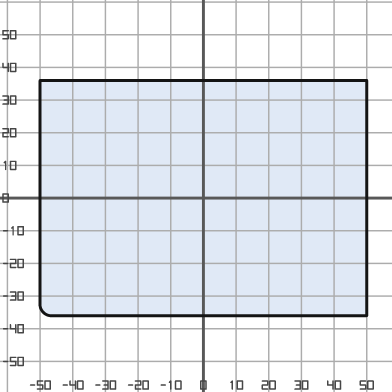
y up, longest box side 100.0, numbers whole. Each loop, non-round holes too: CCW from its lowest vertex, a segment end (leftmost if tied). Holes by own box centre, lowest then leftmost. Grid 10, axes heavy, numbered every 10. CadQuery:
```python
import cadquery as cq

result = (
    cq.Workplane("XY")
    .moveTo(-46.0, -36.0)
    .lineTo(50.0, -36.0)
    .lineTo(50.0, 36.0)
    .lineTo(-50.0, 36.0)
    .lineTo(-50.0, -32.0)
    .threePointArc((-49.0, -35.0), (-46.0, -36.0))
    .close()
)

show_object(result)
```